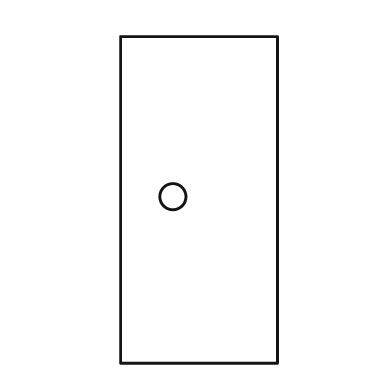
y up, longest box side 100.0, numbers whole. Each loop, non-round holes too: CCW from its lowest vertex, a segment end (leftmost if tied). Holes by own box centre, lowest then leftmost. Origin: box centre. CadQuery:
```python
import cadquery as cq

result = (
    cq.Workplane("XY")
    .moveTo(-24.0, -50.0)
    .lineTo(24.0, -50.0)
    .lineTo(24.0, 50.0)
    .lineTo(-24.0, 50.0)
    .close()
    .moveTo(-8.0, 1.0)
    .circle(4.0)
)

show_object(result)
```